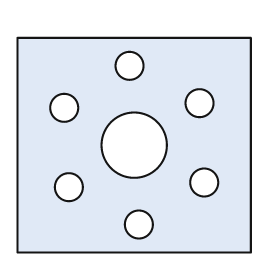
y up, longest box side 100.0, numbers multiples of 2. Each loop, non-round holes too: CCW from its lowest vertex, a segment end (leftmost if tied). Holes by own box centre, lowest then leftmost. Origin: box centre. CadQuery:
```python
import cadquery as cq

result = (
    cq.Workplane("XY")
    .moveTo(-50.0, -46.0)
    .lineTo(50.0, -46.0)
    .lineTo(50.0, 46.0)
    .lineTo(-50.0, 46.0)
    .close()
    .moveTo(2.0, -34.0)
    .circle(6.0)
    .moveTo(-28.0, -18.0)
    .circle(6.0)
    .moveTo(30.0, -16.0)
    .circle(6.0)
    .moveTo(0.0, 0.0)
    .circle(14.0)
    .moveTo(-30.0, 16.0)
    .circle(6.0)
    .moveTo(28.0, 18.0)
    .circle(6.0)
    .moveTo(-2.0, 34.0)
    .circle(6.0)
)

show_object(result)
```